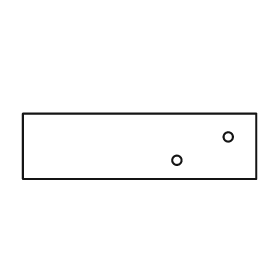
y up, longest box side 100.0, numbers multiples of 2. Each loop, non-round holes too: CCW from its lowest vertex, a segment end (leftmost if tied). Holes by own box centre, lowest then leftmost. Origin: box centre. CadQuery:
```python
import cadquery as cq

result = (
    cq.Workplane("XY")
    .moveTo(-50.0, -14.0)
    .lineTo(50.0, -14.0)
    .lineTo(50.0, 14.0)
    .lineTo(-50.0, 14.0)
    .close()
    .moveTo(16.0, -6.0)
    .circle(2.0)
    .moveTo(38.0, 4.0)
    .circle(2.0)
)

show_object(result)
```